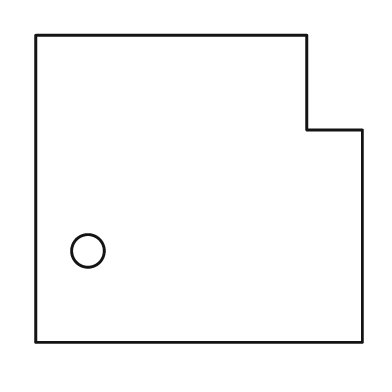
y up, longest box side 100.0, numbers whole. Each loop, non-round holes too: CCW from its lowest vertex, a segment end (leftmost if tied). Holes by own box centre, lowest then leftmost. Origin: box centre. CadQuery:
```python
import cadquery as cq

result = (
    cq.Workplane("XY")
    .moveTo(-50.0, -47.0)
    .lineTo(50.0, -47.0)
    .lineTo(50.0, 18.0)
    .lineTo(33.0, 18.0)
    .lineTo(33.0, 47.0)
    .lineTo(-50.0, 47.0)
    .close()
    .moveTo(-34.0, -19.0)
    .circle(5.0)
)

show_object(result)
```